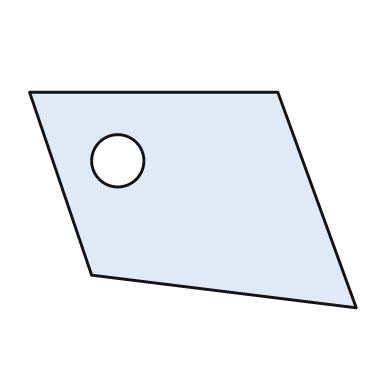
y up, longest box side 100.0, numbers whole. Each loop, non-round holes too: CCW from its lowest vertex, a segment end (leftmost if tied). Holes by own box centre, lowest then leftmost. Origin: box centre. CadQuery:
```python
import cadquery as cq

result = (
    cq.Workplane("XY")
    .moveTo(50.0, -33.0)
    .lineTo(26.0, 33.0)
    .lineTo(-50.0, 33.0)
    .lineTo(-31.0, -23.0)
    .close()
    .moveTo(-23.0, 12.0)
    .circle(8.0)
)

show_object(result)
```